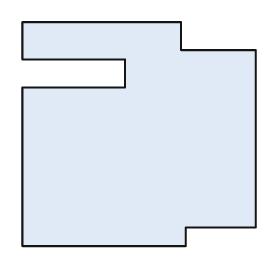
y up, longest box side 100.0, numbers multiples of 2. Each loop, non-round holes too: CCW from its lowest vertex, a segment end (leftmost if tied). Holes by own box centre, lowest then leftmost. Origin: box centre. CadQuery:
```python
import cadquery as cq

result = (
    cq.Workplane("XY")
    .moveTo(-50.0, -48.0)
    .lineTo(20.0, -48.0)
    .lineTo(20.0, -40.0)
    .lineTo(50.0, -40.0)
    .lineTo(50.0, 36.0)
    .lineTo(18.0, 36.0)
    .lineTo(18.0, 48.0)
    .lineTo(-50.0, 48.0)
    .lineTo(-50.0, 32.0)
    .lineTo(-6.0, 32.0)
    .lineTo(-6.0, 20.0)
    .lineTo(-50.0, 20.0)
    .close()
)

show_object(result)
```